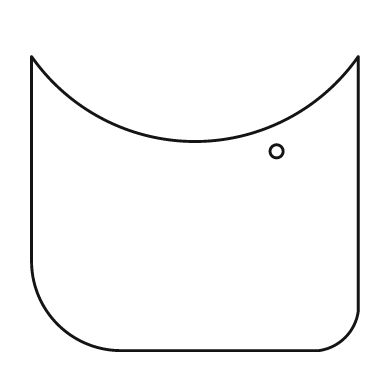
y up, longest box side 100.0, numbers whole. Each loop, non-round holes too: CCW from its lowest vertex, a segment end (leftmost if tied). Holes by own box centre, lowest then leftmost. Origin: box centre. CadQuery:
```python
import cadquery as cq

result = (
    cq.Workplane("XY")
    .moveTo(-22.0, -45.0)
    .lineTo(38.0, -45.0)
    .threePointArc((46.0, -41.0), (50.0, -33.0))
    .lineTo(50.0, 45.0)
    .threePointArc((0.0, 19.0), (-50.0, 45.0))
    .lineTo(-50.0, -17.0)
    .threePointArc((-42.0, -37.0), (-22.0, -45.0))
    .close()
    .moveTo(25.0, 16.0)
    .circle(2.0)
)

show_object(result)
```